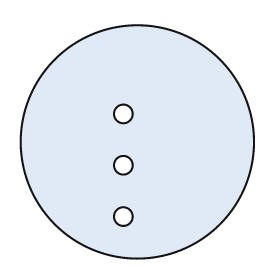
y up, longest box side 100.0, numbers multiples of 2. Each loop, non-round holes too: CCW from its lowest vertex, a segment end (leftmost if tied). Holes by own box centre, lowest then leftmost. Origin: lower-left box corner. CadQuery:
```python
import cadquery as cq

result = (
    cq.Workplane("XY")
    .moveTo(50.0, 50.0)
    .circle(50.0)
    .moveTo(44.0, 18.0)
    .circle(4.0)
    .moveTo(44.0, 40.0)
    .circle(4.0)
    .moveTo(44.0, 62.0)
    .circle(4.0)
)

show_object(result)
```